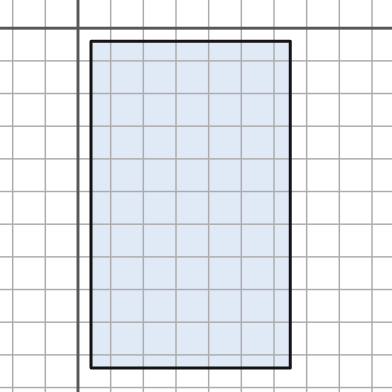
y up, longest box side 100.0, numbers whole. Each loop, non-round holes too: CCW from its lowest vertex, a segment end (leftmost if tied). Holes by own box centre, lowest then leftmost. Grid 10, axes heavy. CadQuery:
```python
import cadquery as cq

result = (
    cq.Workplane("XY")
    .moveTo(4.0, -104.0)
    .lineTo(65.0, -104.0)
    .lineTo(65.0, -4.0)
    .lineTo(4.0, -4.0)
    .close()
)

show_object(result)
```